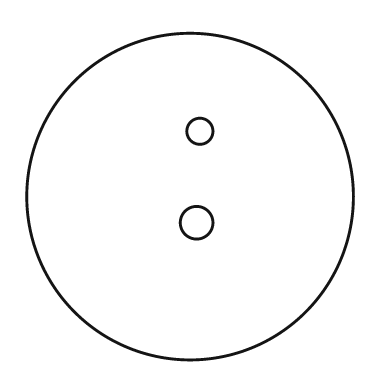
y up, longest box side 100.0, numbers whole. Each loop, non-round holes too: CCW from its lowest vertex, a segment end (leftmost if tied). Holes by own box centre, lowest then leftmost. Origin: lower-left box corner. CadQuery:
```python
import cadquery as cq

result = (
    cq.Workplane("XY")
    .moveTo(50.0, 50.0)
    .circle(50.0)
    .moveTo(52.0, 42.0)
    .circle(5.0)
    .moveTo(53.0, 70.0)
    .circle(4.0)
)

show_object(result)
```